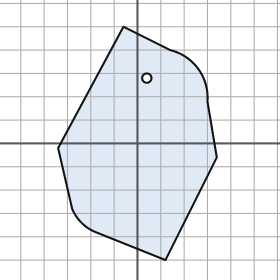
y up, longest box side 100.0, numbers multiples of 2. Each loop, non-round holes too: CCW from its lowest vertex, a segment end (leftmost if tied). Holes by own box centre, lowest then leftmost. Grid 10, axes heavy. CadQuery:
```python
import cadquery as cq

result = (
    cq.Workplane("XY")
    .moveTo(12.0, -50.0)
    .lineTo(34.0, -6.0)
    .lineTo(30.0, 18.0)
    .threePointArc((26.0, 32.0), (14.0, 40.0))
    .lineTo(-6.0, 50.0)
    .lineTo(-34.0, -2.0)
    .lineTo(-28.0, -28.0)
    .threePointArc((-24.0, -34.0), (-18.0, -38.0))
    .close()
    .moveTo(4.0, 28.0)
    .circle(2.0)
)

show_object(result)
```